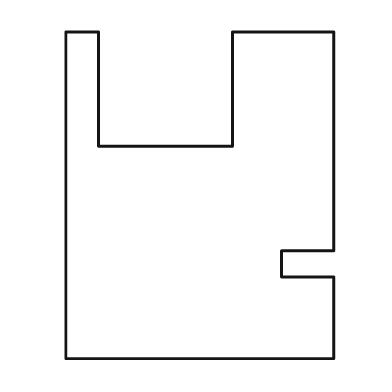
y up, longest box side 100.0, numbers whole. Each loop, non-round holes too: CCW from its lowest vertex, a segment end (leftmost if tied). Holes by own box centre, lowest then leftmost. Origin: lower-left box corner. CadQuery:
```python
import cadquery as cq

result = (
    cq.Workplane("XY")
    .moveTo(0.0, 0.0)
    .lineTo(82.0, 0.0)
    .lineTo(82.0, 25.0)
    .lineTo(66.0, 25.0)
    .lineTo(66.0, 33.0)
    .lineTo(82.0, 33.0)
    .lineTo(82.0, 100.0)
    .lineTo(51.0, 100.0)
    .lineTo(51.0, 65.0)
    .lineTo(10.0, 65.0)
    .lineTo(10.0, 100.0)
    .lineTo(0.0, 100.0)
    .close()
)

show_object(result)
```